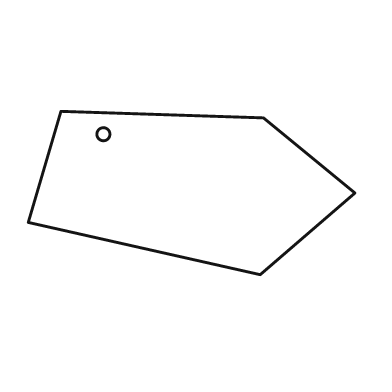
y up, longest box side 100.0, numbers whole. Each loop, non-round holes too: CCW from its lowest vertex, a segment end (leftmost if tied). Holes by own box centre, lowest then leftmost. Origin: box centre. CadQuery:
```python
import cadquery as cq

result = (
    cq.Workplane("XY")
    .moveTo(21.0, -25.0)
    .lineTo(50.0, 0.0)
    .lineTo(22.0, 23.0)
    .lineTo(-40.0, 25.0)
    .lineTo(-50.0, -9.0)
    .close()
    .moveTo(-27.0, 18.0)
    .circle(2.0)
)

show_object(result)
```